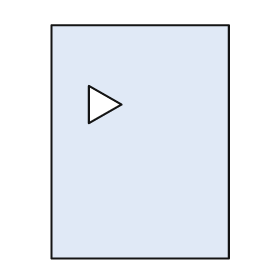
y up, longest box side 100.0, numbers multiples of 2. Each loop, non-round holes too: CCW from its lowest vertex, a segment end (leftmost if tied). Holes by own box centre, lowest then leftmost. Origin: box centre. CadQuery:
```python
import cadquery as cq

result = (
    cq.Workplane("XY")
    .moveTo(-38.0, -50.0)
    .lineTo(38.0, -50.0)
    .lineTo(38.0, 50.0)
    .lineTo(-38.0, 50.0)
    .close()
    .moveTo(-22.0, 8.0)
    .lineTo(-8.0, 16.0)
    .lineTo(-22.0, 24.0)
    .close()
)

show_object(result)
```